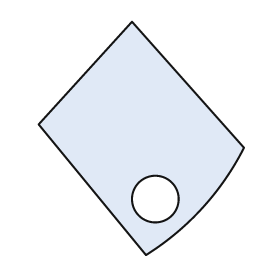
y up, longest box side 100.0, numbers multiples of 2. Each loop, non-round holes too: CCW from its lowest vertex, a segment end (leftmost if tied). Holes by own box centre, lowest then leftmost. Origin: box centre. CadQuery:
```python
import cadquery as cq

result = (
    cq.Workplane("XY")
    .moveTo(2.0, -50.0)
    .threePointArc((26.0, -30.0), (44.0, -4.0))
    .lineTo(-4.0, 50.0)
    .lineTo(-44.0, 6.0)
    .close()
    .moveTo(6.0, -26.0)
    .circle(10.0)
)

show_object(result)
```